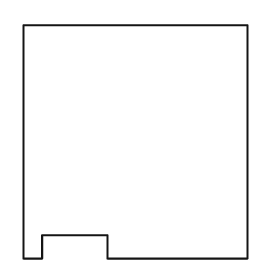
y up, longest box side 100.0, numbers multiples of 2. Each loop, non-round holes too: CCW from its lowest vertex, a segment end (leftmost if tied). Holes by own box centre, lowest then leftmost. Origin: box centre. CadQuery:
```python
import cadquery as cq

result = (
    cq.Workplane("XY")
    .moveTo(-48.0, -50.0)
    .lineTo(-40.0, -50.0)
    .lineTo(-40.0, -40.0)
    .lineTo(-12.0, -40.0)
    .lineTo(-12.0, -50.0)
    .lineTo(48.0, -50.0)
    .lineTo(48.0, 50.0)
    .lineTo(-48.0, 50.0)
    .close()
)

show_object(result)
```